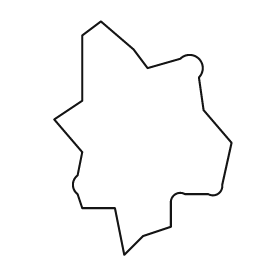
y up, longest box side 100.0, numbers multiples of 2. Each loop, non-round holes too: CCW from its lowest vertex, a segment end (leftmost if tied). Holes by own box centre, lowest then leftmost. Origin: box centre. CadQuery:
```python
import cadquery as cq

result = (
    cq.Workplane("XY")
    .moveTo(-8.0, -50.0)
    .lineTo(0.0, -42.0)
    .lineTo(12.0, -38.0)
    .lineTo(12.0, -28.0)
    .threePointArc((14.0, -24.0), (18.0, -24.0))
    .lineTo(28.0, -24.0)
    .threePointArc((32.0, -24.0), (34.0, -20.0))
    .lineTo(38.0, -2.0)
    .lineTo(26.0, 12.0)
    .lineTo(24.0, 26.0)
    .threePointArc((24.0, 34.0), (16.0, 34.0))
    .lineTo(2.0, 30.0)
    .lineTo(-4.0, 38.0)
    .lineTo(-18.0, 50.0)
    .lineTo(-26.0, 44.0)
    .lineTo(-26.0, 16.0)
    .lineTo(-38.0, 8.0)
    .lineTo(-26.0, -6.0)
    .lineTo(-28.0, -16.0)
    .threePointArc((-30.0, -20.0), (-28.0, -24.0))
    .lineTo(-26.0, -30.0)
    .lineTo(-12.0, -30.0)
    .close()
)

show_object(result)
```